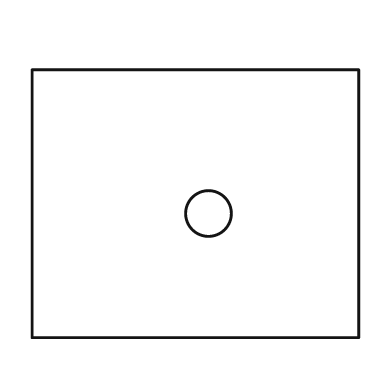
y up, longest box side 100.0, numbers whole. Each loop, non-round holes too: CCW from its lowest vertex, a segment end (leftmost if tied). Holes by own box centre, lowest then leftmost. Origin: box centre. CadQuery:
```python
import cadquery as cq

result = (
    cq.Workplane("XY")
    .moveTo(-50.0, -41.0)
    .lineTo(50.0, -41.0)
    .lineTo(50.0, 41.0)
    .lineTo(-50.0, 41.0)
    .close()
    .moveTo(4.0, -3.0)
    .circle(7.0)
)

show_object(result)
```